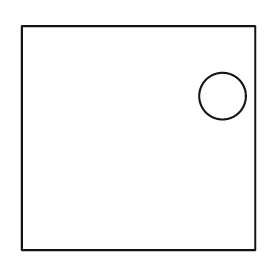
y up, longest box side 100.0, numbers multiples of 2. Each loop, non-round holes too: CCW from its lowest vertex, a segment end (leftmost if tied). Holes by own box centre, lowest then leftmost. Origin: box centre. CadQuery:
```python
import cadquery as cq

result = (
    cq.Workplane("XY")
    .moveTo(-50.0, -48.0)
    .lineTo(50.0, -48.0)
    .lineTo(50.0, 48.0)
    .lineTo(-50.0, 48.0)
    .close()
    .moveTo(36.0, 18.0)
    .circle(10.0)
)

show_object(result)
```